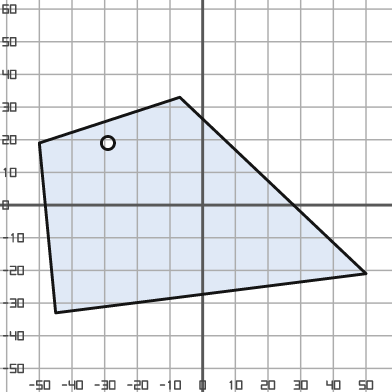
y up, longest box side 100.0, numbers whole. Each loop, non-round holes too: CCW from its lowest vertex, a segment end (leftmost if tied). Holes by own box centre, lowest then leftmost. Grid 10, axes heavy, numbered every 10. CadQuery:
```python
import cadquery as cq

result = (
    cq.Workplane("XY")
    .moveTo(-45.0, -33.0)
    .lineTo(50.0, -21.0)
    .lineTo(-7.0, 33.0)
    .lineTo(-50.0, 19.0)
    .close()
    .moveTo(-29.0, 19.0)
    .circle(2.0)
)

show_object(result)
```